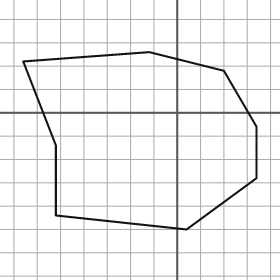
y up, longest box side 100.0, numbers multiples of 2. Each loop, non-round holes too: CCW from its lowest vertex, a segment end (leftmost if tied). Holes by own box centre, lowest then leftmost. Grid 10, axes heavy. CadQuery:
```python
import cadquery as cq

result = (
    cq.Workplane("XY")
    .moveTo(4.0, -50.0)
    .lineTo(34.0, -28.0)
    .lineTo(34.0, -6.0)
    .lineTo(20.0, 18.0)
    .lineTo(-12.0, 26.0)
    .lineTo(-66.0, 22.0)
    .lineTo(-52.0, -14.0)
    .lineTo(-52.0, -44.0)
    .close()
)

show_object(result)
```